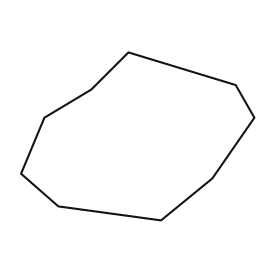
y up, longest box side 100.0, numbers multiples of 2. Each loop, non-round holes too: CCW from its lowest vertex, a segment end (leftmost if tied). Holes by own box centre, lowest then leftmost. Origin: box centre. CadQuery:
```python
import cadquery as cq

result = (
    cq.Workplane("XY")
    .moveTo(10.0, -36.0)
    .lineTo(32.0, -18.0)
    .lineTo(50.0, 8.0)
    .lineTo(42.0, 22.0)
    .lineTo(-4.0, 36.0)
    .lineTo(-20.0, 20.0)
    .lineTo(-40.0, 8.0)
    .lineTo(-50.0, -16.0)
    .lineTo(-34.0, -30.0)
    .close()
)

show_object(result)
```